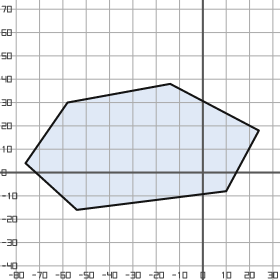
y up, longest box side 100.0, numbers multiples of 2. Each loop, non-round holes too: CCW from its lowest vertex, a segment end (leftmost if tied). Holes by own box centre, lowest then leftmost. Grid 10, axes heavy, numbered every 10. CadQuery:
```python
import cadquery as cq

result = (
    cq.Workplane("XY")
    .moveTo(-54.0, -16.0)
    .lineTo(10.0, -8.0)
    .lineTo(24.0, 18.0)
    .lineTo(-14.0, 38.0)
    .lineTo(-58.0, 30.0)
    .lineTo(-76.0, 4.0)
    .close()
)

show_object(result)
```